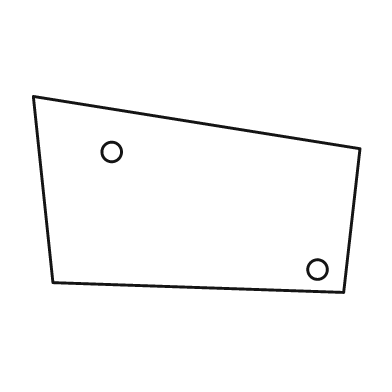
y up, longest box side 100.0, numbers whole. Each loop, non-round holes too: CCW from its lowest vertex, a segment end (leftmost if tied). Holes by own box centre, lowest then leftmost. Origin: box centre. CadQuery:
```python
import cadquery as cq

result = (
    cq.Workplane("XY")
    .moveTo(45.0, -30.0)
    .lineTo(50.0, 14.0)
    .lineTo(-50.0, 30.0)
    .lineTo(-44.0, -27.0)
    .close()
    .moveTo(37.0, -23.0)
    .circle(3.0)
    .moveTo(-26.0, 13.0)
    .circle(3.0)
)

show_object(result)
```